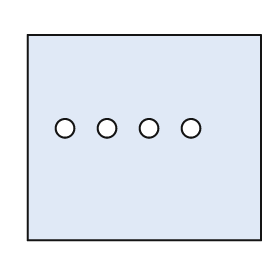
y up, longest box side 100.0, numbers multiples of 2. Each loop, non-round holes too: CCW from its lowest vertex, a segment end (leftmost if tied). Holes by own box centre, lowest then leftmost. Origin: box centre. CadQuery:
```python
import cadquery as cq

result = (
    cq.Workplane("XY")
    .moveTo(-50.0, -44.0)
    .lineTo(50.0, -44.0)
    .lineTo(50.0, 44.0)
    .lineTo(-50.0, 44.0)
    .close()
    .moveTo(-34.0, 4.0)
    .circle(4.0)
    .moveTo(-16.0, 4.0)
    .circle(4.0)
    .moveTo(2.0, 4.0)
    .circle(4.0)
    .moveTo(20.0, 4.0)
    .circle(4.0)
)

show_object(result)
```